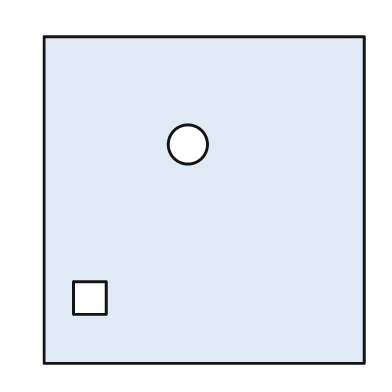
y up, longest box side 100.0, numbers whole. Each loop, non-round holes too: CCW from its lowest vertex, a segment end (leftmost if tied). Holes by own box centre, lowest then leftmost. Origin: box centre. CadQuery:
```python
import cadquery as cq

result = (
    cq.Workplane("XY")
    .moveTo(-49.0, -50.0)
    .lineTo(49.0, -50.0)
    .lineTo(49.0, 50.0)
    .lineTo(-49.0, 50.0)
    .close()
    .moveTo(-40.0, -35.0)
    .lineTo(-30.0, -35.0)
    .lineTo(-30.0, -25.0)
    .lineTo(-40.0, -25.0)
    .close()
    .moveTo(-5.0, 17.0)
    .circle(6.0)
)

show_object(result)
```